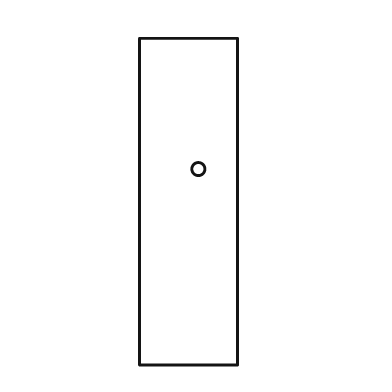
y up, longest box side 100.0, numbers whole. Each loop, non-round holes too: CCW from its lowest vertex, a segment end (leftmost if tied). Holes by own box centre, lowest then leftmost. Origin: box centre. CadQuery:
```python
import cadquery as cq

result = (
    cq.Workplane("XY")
    .moveTo(-15.0, -50.0)
    .lineTo(15.0, -50.0)
    .lineTo(15.0, 50.0)
    .lineTo(-15.0, 50.0)
    .close()
    .moveTo(3.0, 10.0)
    .circle(2.0)
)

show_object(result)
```